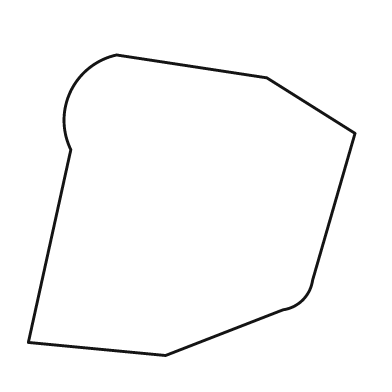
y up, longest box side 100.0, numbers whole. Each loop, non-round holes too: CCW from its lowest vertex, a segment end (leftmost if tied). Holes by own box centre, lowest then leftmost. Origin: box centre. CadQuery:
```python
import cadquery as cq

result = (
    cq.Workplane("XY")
    .moveTo(-8.0, -46.0)
    .lineTo(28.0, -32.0)
    .threePointArc((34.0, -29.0), (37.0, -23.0))
    .lineTo(50.0, 22.0)
    .lineTo(23.0, 39.0)
    .lineTo(-23.0, 46.0)
    .threePointArc((-37.0, 35.0), (-37.0, 17.0))
    .lineTo(-50.0, -42.0)
    .close()
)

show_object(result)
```